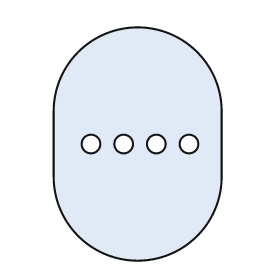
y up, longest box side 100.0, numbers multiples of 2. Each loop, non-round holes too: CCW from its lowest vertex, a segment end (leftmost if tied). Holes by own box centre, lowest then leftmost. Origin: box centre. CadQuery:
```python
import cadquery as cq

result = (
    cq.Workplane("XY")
    .moveTo(-36.0, -14.0)
    .threePointArc((0.0, -50.0), (36.0, -14.0))
    .lineTo(36.0, 14.0)
    .threePointArc((0.0, 50.0), (-36.0, 14.0))
    .close()
    .moveTo(-20.0, 0.0)
    .circle(4.0)
    .moveTo(-6.0, 0.0)
    .circle(4.0)
    .moveTo(8.0, 0.0)
    .circle(4.0)
    .moveTo(22.0, 0.0)
    .circle(4.0)
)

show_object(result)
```